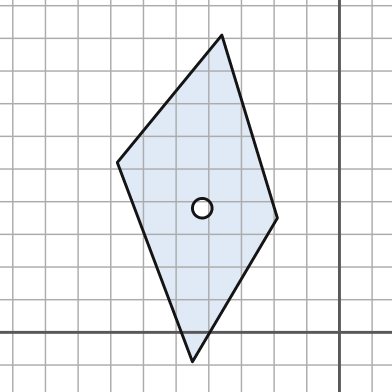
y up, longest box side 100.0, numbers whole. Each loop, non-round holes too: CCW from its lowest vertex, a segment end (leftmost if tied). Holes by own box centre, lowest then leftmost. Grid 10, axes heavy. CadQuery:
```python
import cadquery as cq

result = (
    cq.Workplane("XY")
    .moveTo(-45.0, -9.0)
    .lineTo(-19.0, 35.0)
    .lineTo(-36.0, 91.0)
    .lineTo(-68.0, 52.0)
    .close()
    .moveTo(-42.0, 38.0)
    .circle(3.0)
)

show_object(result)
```